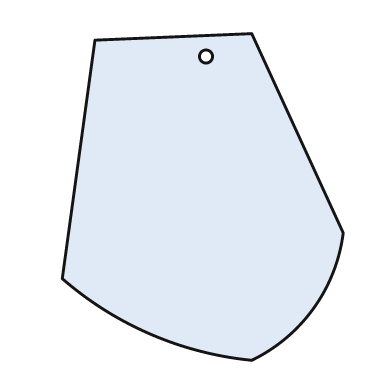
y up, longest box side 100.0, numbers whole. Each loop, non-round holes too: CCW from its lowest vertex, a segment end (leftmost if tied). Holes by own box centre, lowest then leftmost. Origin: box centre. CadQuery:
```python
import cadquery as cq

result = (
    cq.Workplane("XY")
    .moveTo(15.0, -50.0)
    .threePointArc((34.0, -34.0), (43.0, -11.0))
    .lineTo(15.0, 50.0)
    .lineTo(-33.0, 48.0)
    .lineTo(-43.0, -25.0)
    .threePointArc((-16.0, -42.0), (15.0, -50.0))
    .close()
    .moveTo(1.0, 43.0)
    .circle(2.0)
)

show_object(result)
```